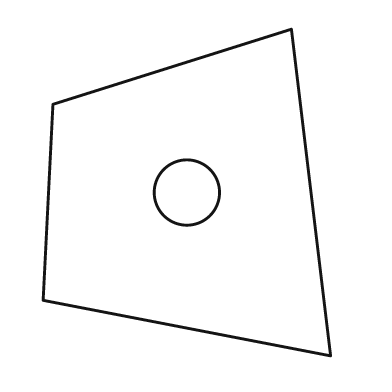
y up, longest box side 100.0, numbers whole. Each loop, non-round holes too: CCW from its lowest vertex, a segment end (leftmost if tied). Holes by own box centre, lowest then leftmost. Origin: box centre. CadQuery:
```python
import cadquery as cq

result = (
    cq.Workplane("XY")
    .moveTo(44.0, -50.0)
    .lineTo(32.0, 50.0)
    .lineTo(-41.0, 27.0)
    .lineTo(-44.0, -33.0)
    .close()
    .moveTo(0.0, 0.0)
    .circle(10.0)
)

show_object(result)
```